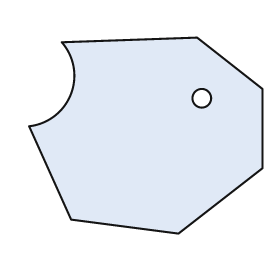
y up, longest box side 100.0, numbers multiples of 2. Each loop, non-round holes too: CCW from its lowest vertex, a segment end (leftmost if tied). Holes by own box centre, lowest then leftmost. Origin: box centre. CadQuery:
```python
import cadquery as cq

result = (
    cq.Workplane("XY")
    .moveTo(14.0, -42.0)
    .lineTo(50.0, -14.0)
    .lineTo(50.0, 20.0)
    .lineTo(22.0, 42.0)
    .lineTo(-36.0, 40.0)
    .threePointArc((-32.0, 18.0), (-50.0, 4.0))
    .lineTo(-32.0, -36.0)
    .close()
    .moveTo(24.0, 16.0)
    .circle(4.0)
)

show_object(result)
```